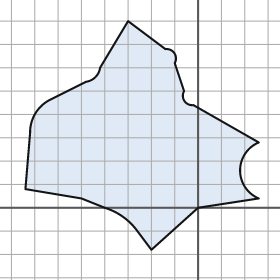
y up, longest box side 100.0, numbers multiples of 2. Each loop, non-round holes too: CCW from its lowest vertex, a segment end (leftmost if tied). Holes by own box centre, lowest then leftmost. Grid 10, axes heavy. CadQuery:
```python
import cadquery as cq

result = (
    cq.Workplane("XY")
    .moveTo(-20.0, -18.0)
    .lineTo(0.0, 0.0)
    .lineTo(26.0, 4.0)
    .threePointArc((18.0, 16.0), (26.0, 28.0))
    .lineTo(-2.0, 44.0)
    .threePointArc((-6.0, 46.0), (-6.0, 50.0))
    .lineTo(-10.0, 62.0)
    .threePointArc((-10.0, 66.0), (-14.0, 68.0))
    .lineTo(-30.0, 80.0)
    .lineTo(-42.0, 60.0)
    .threePointArc((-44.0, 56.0), (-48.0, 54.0))
    .lineTo(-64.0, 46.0)
    .threePointArc((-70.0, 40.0), (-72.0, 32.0))
    .lineTo(-74.0, 8.0)
    .lineTo(-50.0, 4.0)
    .lineTo(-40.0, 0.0)
    .threePointArc((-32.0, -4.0), (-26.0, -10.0))
    .close()
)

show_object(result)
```